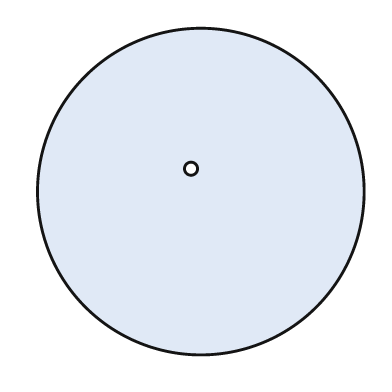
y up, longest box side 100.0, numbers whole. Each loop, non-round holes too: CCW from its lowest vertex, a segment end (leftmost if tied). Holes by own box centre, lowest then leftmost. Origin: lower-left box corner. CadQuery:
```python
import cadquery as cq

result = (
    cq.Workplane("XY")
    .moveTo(50.0, 50.0)
    .circle(50.0)
    .moveTo(47.0, 57.0)
    .circle(2.0)
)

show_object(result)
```